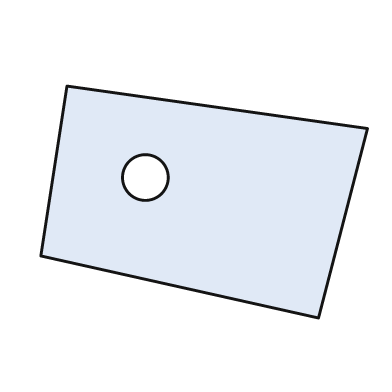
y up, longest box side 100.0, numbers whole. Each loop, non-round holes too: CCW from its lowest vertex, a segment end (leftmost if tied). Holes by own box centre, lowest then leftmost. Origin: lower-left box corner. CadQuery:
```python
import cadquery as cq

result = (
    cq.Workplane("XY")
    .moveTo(85.0, 0.0)
    .lineTo(100.0, 58.0)
    .lineTo(8.0, 71.0)
    .lineTo(0.0, 19.0)
    .close()
    .moveTo(32.0, 43.0)
    .circle(7.0)
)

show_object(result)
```